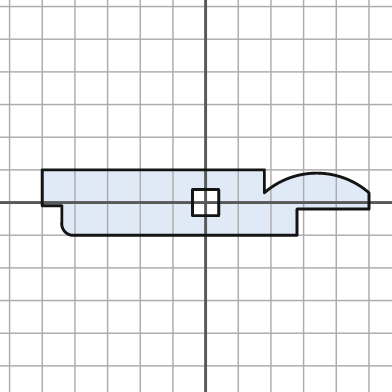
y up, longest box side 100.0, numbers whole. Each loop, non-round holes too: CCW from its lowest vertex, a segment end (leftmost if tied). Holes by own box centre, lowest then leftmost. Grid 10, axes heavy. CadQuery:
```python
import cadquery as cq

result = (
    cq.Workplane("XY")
    .moveTo(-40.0, -10.0)
    .lineTo(28.0, -10.0)
    .lineTo(28.0, -2.0)
    .lineTo(50.0, -2.0)
    .lineTo(50.0, 3.0)
    .threePointArc((34.0, 9.0), (18.0, 3.0))
    .lineTo(18.0, 10.0)
    .lineTo(-50.0, 10.0)
    .lineTo(-50.0, -1.0)
    .lineTo(-44.0, -1.0)
    .lineTo(-44.0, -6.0)
    .threePointArc((-43.0, -9.0), (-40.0, -10.0))
    .close()
    .moveTo(-4.0, -4.0)
    .lineTo(4.0, -4.0)
    .lineTo(4.0, 4.0)
    .lineTo(-4.0, 4.0)
    .close()
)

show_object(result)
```